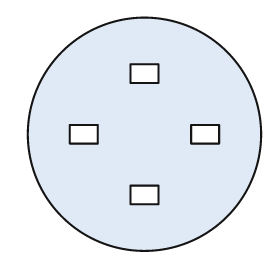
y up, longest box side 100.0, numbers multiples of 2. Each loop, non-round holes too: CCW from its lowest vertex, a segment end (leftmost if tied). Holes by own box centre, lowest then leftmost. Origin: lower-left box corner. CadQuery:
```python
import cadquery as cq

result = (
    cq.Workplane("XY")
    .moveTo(50.0, 50.0)
    .circle(50.0)
    .moveTo(44.0, 20.0)
    .lineTo(56.0, 20.0)
    .lineTo(56.0, 28.0)
    .lineTo(44.0, 28.0)
    .close()
    .moveTo(18.0, 46.0)
    .lineTo(30.0, 46.0)
    .lineTo(30.0, 54.0)
    .lineTo(18.0, 54.0)
    .close()
    .moveTo(70.0, 46.0)
    .lineTo(82.0, 46.0)
    .lineTo(82.0, 54.0)
    .lineTo(70.0, 54.0)
    .close()
    .moveTo(44.0, 72.0)
    .lineTo(56.0, 72.0)
    .lineTo(56.0, 80.0)
    .lineTo(44.0, 80.0)
    .close()
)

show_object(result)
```